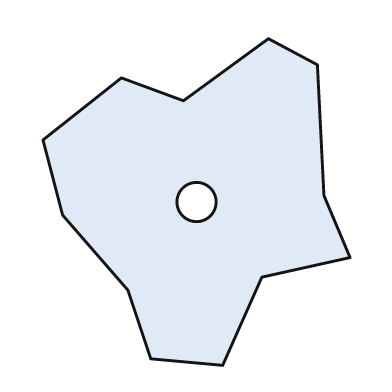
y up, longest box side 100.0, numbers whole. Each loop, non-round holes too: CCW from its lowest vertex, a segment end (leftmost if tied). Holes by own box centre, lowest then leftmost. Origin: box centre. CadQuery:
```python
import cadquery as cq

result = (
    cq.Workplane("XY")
    .moveTo(8.0, -50.0)
    .lineTo(20.0, -23.0)
    .lineTo(47.0, -17.0)
    .lineTo(39.0, 2.0)
    .lineTo(37.0, 42.0)
    .lineTo(22.0, 50.0)
    .lineTo(-4.0, 31.0)
    .lineTo(-23.0, 38.0)
    .lineTo(-47.0, 19.0)
    .lineTo(-41.0, -4.0)
    .lineTo(-21.0, -27.0)
    .lineTo(-14.0, -48.0)
    .close()
    .moveTo(0.0, 0.0)
    .circle(6.0)
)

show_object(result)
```